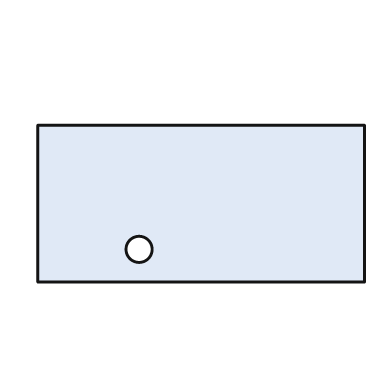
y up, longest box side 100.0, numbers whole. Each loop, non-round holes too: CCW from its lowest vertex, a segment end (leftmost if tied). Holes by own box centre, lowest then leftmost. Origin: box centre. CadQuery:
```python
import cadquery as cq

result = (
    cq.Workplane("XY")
    .moveTo(-50.0, -24.0)
    .lineTo(50.0, -24.0)
    .lineTo(50.0, 24.0)
    .lineTo(-50.0, 24.0)
    .close()
    .moveTo(-19.0, -14.0)
    .circle(4.0)
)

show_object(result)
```